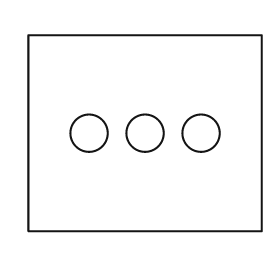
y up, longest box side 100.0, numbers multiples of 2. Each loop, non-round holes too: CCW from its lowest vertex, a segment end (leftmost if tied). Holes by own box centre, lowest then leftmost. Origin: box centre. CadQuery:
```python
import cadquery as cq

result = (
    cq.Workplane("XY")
    .moveTo(-50.0, -42.0)
    .lineTo(50.0, -42.0)
    .lineTo(50.0, 42.0)
    .lineTo(-50.0, 42.0)
    .close()
    .moveTo(-24.0, 0.0)
    .circle(8.0)
    .moveTo(0.0, 0.0)
    .circle(8.0)
    .moveTo(24.0, 0.0)
    .circle(8.0)
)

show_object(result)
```